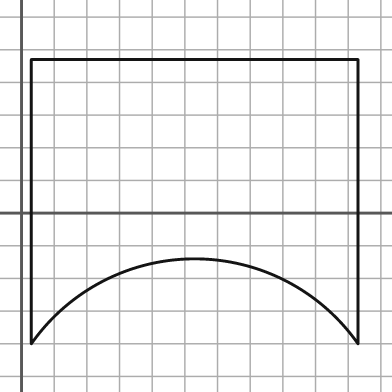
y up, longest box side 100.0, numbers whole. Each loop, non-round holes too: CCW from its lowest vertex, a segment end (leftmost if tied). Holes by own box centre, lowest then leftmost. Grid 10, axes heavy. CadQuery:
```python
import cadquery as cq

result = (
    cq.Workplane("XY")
    .moveTo(3.0, -40.0)
    .threePointArc((53.0, -14.0), (103.0, -40.0))
    .lineTo(103.0, 47.0)
    .lineTo(3.0, 47.0)
    .close()
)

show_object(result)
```